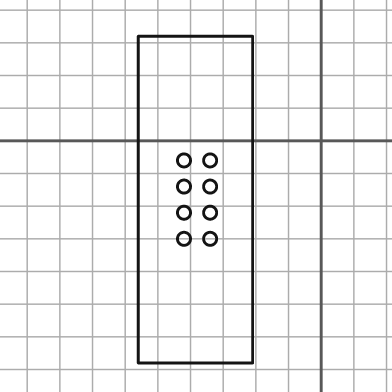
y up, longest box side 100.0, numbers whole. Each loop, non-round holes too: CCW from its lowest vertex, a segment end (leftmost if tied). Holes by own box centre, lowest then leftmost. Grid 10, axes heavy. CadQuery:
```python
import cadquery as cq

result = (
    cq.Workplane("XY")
    .moveTo(-56.0, -68.0)
    .lineTo(-21.0, -68.0)
    .lineTo(-21.0, 32.0)
    .lineTo(-56.0, 32.0)
    .close()
    .moveTo(-42.0, -30.0)
    .circle(2.0)
    .moveTo(-34.0, -30.0)
    .circle(2.0)
    .moveTo(-42.0, -22.0)
    .circle(2.0)
    .moveTo(-34.0, -22.0)
    .circle(2.0)
    .moveTo(-42.0, -14.0)
    .circle(2.0)
    .moveTo(-34.0, -14.0)
    .circle(2.0)
    .moveTo(-42.0, -6.0)
    .circle(2.0)
    .moveTo(-34.0, -6.0)
    .circle(2.0)
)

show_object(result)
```